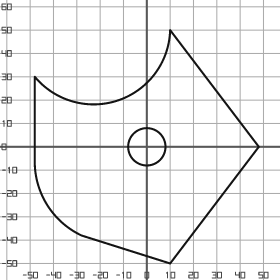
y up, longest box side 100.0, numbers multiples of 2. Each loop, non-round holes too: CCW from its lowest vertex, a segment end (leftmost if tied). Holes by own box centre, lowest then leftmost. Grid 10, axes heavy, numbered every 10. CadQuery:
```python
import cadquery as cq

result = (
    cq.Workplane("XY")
    .moveTo(10.0, -50.0)
    .lineTo(48.0, 0.0)
    .lineTo(10.0, 50.0)
    .threePointArc((-12.0, 20.0), (-48.0, 30.0))
    .lineTo(-48.0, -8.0)
    .threePointArc((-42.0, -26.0), (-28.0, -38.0))
    .close()
    .moveTo(0.0, 0.0)
    .circle(8.0)
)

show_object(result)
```